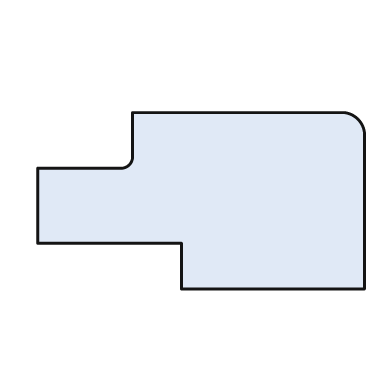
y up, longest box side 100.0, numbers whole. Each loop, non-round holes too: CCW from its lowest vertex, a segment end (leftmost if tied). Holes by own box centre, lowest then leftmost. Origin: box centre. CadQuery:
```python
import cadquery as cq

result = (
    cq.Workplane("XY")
    .moveTo(-6.0, -27.0)
    .lineTo(50.0, -27.0)
    .lineTo(50.0, 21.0)
    .threePointArc((48.0, 25.0), (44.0, 27.0))
    .lineTo(-21.0, 27.0)
    .lineTo(-21.0, 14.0)
    .threePointArc((-22.0, 11.0), (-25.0, 10.0))
    .lineTo(-50.0, 10.0)
    .lineTo(-50.0, -13.0)
    .lineTo(-6.0, -13.0)
    .close()
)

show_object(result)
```